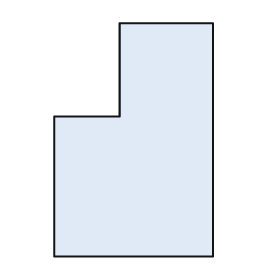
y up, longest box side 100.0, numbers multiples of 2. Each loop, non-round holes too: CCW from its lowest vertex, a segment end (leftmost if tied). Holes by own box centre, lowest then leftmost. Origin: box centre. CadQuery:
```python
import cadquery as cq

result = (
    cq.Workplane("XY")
    .moveTo(-34.0, -50.0)
    .lineTo(34.0, -50.0)
    .lineTo(34.0, 50.0)
    .lineTo(-6.0, 50.0)
    .lineTo(-6.0, 10.0)
    .lineTo(-34.0, 10.0)
    .close()
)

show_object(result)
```